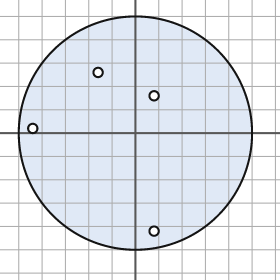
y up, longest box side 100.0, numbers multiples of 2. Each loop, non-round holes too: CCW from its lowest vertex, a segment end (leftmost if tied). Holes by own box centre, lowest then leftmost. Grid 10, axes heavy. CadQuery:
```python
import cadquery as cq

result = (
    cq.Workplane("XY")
    .moveTo(0.0, 0.0)
    .circle(50.0)
    .moveTo(8.0, -42.0)
    .circle(2.0)
    .moveTo(-44.0, 2.0)
    .circle(2.0)
    .moveTo(8.0, 16.0)
    .circle(2.0)
    .moveTo(-16.0, 26.0)
    .circle(2.0)
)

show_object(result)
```